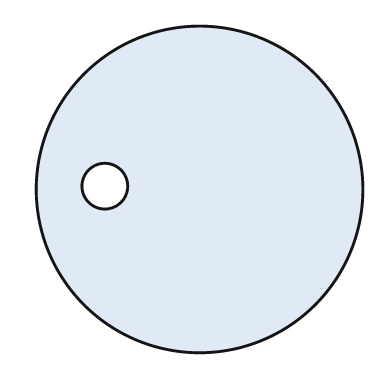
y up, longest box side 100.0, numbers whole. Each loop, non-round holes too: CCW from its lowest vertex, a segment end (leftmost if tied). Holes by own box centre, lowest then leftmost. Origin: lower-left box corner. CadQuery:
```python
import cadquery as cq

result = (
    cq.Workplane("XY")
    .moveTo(50.0, 50.0)
    .circle(50.0)
    .moveTo(21.0, 51.0)
    .circle(7.0)
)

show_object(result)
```